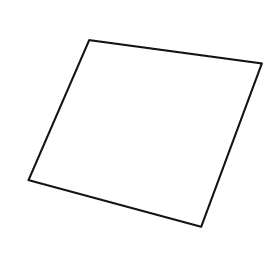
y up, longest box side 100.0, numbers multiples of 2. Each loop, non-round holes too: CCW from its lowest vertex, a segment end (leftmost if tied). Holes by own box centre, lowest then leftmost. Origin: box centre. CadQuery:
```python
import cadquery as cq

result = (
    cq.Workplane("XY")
    .moveTo(24.0, -40.0)
    .lineTo(50.0, 30.0)
    .lineTo(-24.0, 40.0)
    .lineTo(-50.0, -20.0)
    .close()
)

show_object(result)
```